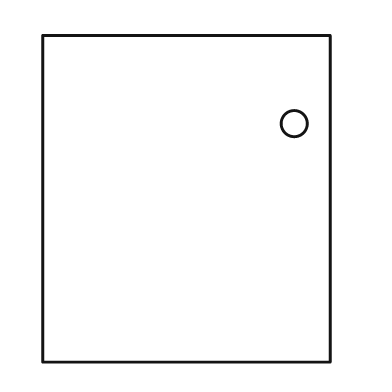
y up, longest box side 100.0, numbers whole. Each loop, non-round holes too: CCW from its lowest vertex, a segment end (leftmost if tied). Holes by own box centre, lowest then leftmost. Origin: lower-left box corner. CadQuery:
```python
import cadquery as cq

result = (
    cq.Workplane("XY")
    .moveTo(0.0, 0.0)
    .lineTo(88.0, 0.0)
    .lineTo(88.0, 100.0)
    .lineTo(0.0, 100.0)
    .close()
    .moveTo(77.0, 73.0)
    .circle(4.0)
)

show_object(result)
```